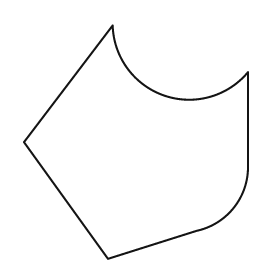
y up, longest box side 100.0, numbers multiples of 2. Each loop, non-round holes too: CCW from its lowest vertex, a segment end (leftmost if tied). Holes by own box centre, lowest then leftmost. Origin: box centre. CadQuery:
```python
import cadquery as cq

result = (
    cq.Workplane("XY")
    .moveTo(-12.0, -50.0)
    .lineTo(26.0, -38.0)
    .threePointArc((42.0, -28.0), (48.0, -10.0))
    .lineTo(48.0, 30.0)
    .threePointArc((12.0, 20.0), (-10.0, 50.0))
    .lineTo(-48.0, 0.0)
    .close()
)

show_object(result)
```